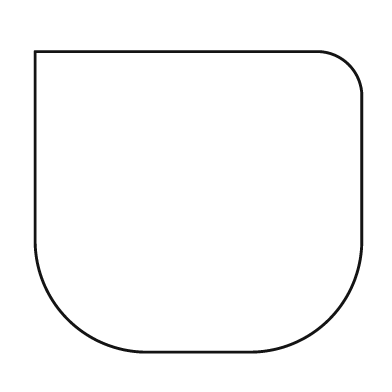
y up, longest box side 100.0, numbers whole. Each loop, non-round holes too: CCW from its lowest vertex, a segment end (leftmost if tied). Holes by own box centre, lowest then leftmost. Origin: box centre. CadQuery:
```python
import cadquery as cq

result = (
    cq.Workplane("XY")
    .moveTo(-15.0, -46.0)
    .lineTo(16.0, -46.0)
    .threePointArc((40.0, -36.0), (50.0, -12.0))
    .lineTo(50.0, 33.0)
    .threePointArc((46.0, 42.0), (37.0, 46.0))
    .lineTo(-50.0, 46.0)
    .lineTo(-50.0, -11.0)
    .threePointArc((-40.0, -36.0), (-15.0, -46.0))
    .close()
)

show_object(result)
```